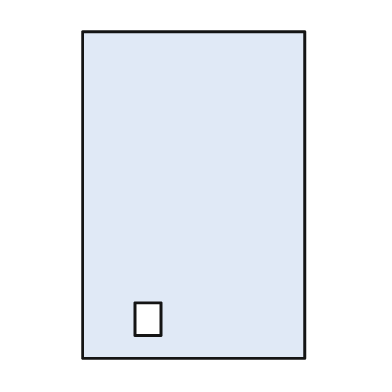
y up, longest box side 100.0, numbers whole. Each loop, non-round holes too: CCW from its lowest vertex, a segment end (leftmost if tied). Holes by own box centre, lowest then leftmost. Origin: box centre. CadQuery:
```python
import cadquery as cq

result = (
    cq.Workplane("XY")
    .moveTo(-34.0, -50.0)
    .lineTo(34.0, -50.0)
    .lineTo(34.0, 50.0)
    .lineTo(-34.0, 50.0)
    .close()
    .moveTo(-18.0, -43.0)
    .lineTo(-10.0, -43.0)
    .lineTo(-10.0, -33.0)
    .lineTo(-18.0, -33.0)
    .close()
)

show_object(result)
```